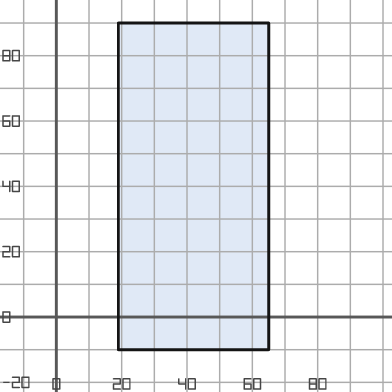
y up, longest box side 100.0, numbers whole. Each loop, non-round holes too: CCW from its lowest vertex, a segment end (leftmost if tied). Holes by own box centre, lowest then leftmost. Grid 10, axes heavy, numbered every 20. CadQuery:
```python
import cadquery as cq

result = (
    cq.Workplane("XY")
    .moveTo(19.0, -10.0)
    .lineTo(65.0, -10.0)
    .lineTo(65.0, 90.0)
    .lineTo(19.0, 90.0)
    .close()
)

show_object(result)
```